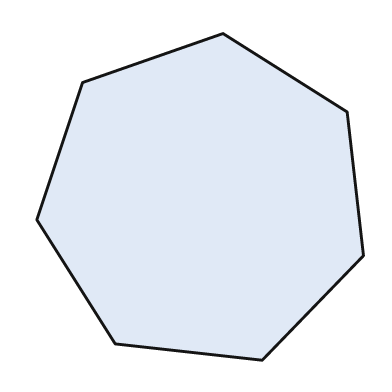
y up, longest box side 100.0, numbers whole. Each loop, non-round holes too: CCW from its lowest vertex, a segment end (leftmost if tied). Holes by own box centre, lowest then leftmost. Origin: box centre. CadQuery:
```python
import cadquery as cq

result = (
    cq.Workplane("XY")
    .moveTo(19.0, -50.0)
    .lineTo(50.0, -18.0)
    .lineTo(45.0, 26.0)
    .lineTo(7.0, 50.0)
    .lineTo(-36.0, 35.0)
    .lineTo(-50.0, -7.0)
    .lineTo(-26.0, -45.0)
    .close()
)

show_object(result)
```